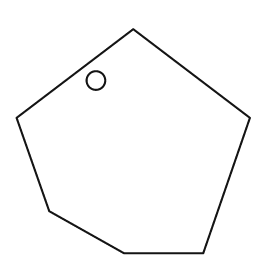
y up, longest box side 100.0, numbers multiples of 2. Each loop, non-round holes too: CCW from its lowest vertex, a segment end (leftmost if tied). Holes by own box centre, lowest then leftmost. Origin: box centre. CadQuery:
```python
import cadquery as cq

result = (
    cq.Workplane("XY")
    .moveTo(-4.0, -48.0)
    .lineTo(30.0, -48.0)
    .lineTo(50.0, 10.0)
    .lineTo(0.0, 48.0)
    .lineTo(-50.0, 10.0)
    .lineTo(-36.0, -30.0)
    .close()
    .moveTo(-16.0, 26.0)
    .circle(4.0)
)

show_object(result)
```